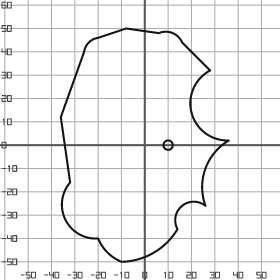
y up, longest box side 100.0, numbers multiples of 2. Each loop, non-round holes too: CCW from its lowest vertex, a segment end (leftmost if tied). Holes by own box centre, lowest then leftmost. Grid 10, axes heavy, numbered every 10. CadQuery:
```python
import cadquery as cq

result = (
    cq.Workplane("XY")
    .moveTo(-10.0, -50.0)
    .threePointArc((4.0, -46.0), (14.0, -36.0))
    .threePointArc((16.0, -26.0), (26.0, -26.0))
    .threePointArc((26.0, -10.0), (36.0, 2.0))
    .threePointArc((20.0, 14.0), (28.0, 32.0))
    .lineTo(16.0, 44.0)
    .threePointArc((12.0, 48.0), (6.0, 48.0))
    .lineTo(-8.0, 50.0)
    .lineTo(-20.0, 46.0)
    .threePointArc((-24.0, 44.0), (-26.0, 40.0))
    .lineTo(-36.0, 12.0)
    .lineTo(-32.0, -16.0)
    .threePointArc((-34.0, -32.0), (-20.0, -40.0))
    .threePointArc((-16.0, -46.0), (-10.0, -50.0))
    .close()
    .moveTo(10.0, 0.0)
    .circle(2.0)
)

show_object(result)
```